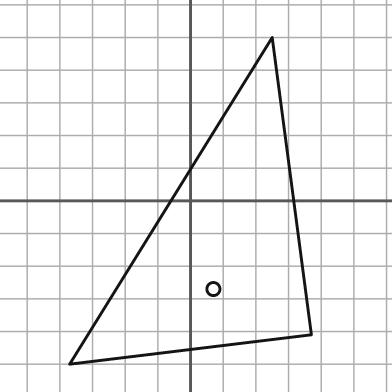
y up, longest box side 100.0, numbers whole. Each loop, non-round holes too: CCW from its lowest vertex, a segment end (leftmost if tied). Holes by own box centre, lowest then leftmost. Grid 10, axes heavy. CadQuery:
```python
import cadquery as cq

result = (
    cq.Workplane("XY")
    .moveTo(-37.0, -50.0)
    .lineTo(37.0, -41.0)
    .lineTo(25.0, 50.0)
    .close()
    .moveTo(7.0, -27.0)
    .circle(2.0)
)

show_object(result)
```